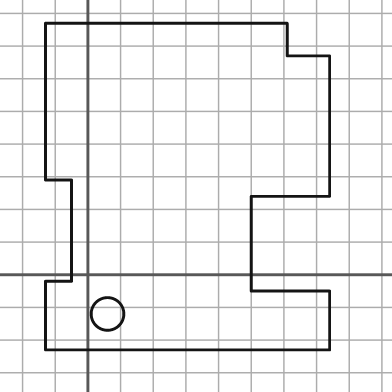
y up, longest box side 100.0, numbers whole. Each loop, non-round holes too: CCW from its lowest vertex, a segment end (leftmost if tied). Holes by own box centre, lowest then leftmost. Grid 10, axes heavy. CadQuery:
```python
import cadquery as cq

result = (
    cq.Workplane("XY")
    .moveTo(-13.0, -23.0)
    .lineTo(74.0, -23.0)
    .lineTo(74.0, -5.0)
    .lineTo(50.0, -5.0)
    .lineTo(50.0, 24.0)
    .lineTo(74.0, 24.0)
    .lineTo(74.0, 67.0)
    .lineTo(61.0, 67.0)
    .lineTo(61.0, 77.0)
    .lineTo(-13.0, 77.0)
    .lineTo(-13.0, 29.0)
    .lineTo(-5.0, 29.0)
    .lineTo(-5.0, -2.0)
    .lineTo(-13.0, -2.0)
    .close()
    .moveTo(6.0, -12.0)
    .circle(5.0)
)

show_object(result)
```